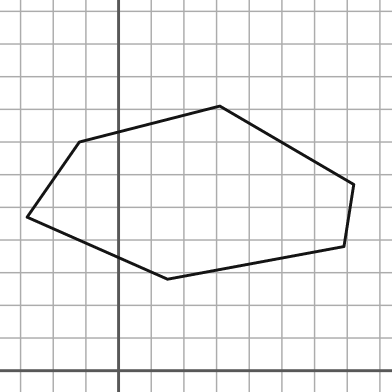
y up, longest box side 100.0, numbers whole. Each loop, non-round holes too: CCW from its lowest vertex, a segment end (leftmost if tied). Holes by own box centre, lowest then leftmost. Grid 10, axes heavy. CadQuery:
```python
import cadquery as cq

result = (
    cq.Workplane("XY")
    .moveTo(15.0, 28.0)
    .lineTo(69.0, 38.0)
    .lineTo(72.0, 57.0)
    .lineTo(31.0, 81.0)
    .lineTo(-12.0, 70.0)
    .lineTo(-28.0, 47.0)
    .close()
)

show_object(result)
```